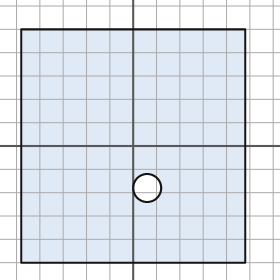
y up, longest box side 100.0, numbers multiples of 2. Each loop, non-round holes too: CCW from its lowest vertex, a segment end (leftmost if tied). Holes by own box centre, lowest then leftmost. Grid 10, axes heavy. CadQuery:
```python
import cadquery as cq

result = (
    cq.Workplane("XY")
    .moveTo(-48.0, -50.0)
    .lineTo(48.0, -50.0)
    .lineTo(48.0, 50.0)
    .lineTo(-48.0, 50.0)
    .close()
    .moveTo(6.0, -18.0)
    .circle(6.0)
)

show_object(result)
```